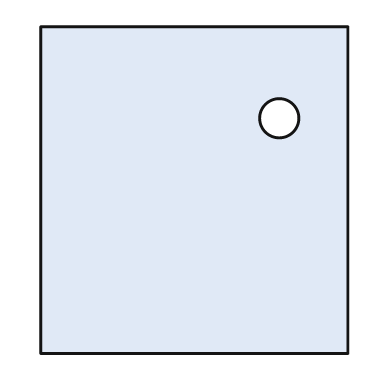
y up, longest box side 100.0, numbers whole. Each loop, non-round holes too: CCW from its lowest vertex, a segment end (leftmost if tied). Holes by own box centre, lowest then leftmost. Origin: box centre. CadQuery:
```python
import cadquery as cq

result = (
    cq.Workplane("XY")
    .moveTo(-47.0, -50.0)
    .lineTo(47.0, -50.0)
    .lineTo(47.0, 50.0)
    .lineTo(-47.0, 50.0)
    .close()
    .moveTo(26.0, 22.0)
    .circle(6.0)
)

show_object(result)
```